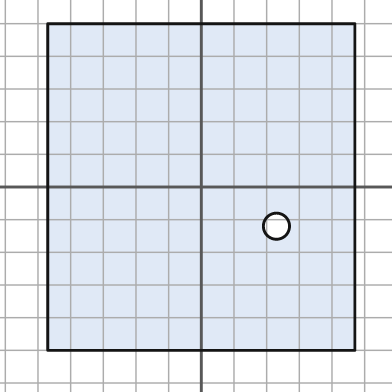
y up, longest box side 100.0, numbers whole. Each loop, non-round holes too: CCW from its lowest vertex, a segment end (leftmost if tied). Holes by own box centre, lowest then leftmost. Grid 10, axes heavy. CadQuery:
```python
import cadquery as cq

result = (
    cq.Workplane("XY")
    .moveTo(-47.0, -50.0)
    .lineTo(47.0, -50.0)
    .lineTo(47.0, 50.0)
    .lineTo(-47.0, 50.0)
    .close()
    .moveTo(23.0, -12.0)
    .circle(4.0)
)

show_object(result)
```